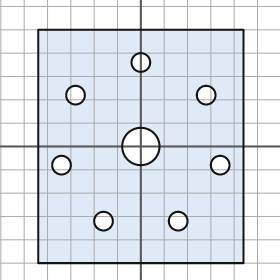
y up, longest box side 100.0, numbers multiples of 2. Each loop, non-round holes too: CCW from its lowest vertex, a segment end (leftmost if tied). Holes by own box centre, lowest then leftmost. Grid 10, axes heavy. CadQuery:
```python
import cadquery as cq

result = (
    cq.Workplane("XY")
    .moveTo(-44.0, -50.0)
    .lineTo(44.0, -50.0)
    .lineTo(44.0, 50.0)
    .lineTo(-44.0, 50.0)
    .close()
    .moveTo(-16.0, -32.0)
    .circle(4.0)
    .moveTo(16.0, -32.0)
    .circle(4.0)
    .moveTo(-34.0, -8.0)
    .circle(4.0)
    .moveTo(34.0, -8.0)
    .circle(4.0)
    .moveTo(0.0, 0.0)
    .circle(8.0)
    .moveTo(-28.0, 22.0)
    .circle(4.0)
    .moveTo(28.0, 22.0)
    .circle(4.0)
    .moveTo(0.0, 36.0)
    .circle(4.0)
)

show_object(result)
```